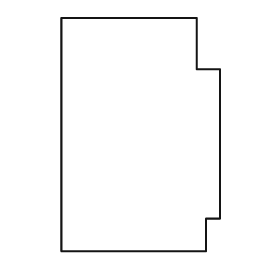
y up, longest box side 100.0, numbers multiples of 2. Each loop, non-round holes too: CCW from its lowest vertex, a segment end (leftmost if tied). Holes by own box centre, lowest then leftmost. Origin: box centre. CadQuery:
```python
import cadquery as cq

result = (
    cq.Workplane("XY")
    .moveTo(-34.0, -50.0)
    .lineTo(28.0, -50.0)
    .lineTo(28.0, -36.0)
    .lineTo(34.0, -36.0)
    .lineTo(34.0, 28.0)
    .lineTo(24.0, 28.0)
    .lineTo(24.0, 50.0)
    .lineTo(-34.0, 50.0)
    .close()
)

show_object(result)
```